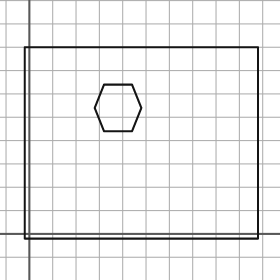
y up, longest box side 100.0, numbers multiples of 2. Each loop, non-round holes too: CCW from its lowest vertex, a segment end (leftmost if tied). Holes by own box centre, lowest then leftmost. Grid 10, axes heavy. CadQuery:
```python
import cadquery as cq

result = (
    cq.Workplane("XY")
    .moveTo(-2.0, -2.0)
    .lineTo(98.0, -2.0)
    .lineTo(98.0, 80.0)
    .lineTo(-2.0, 80.0)
    .close()
    .moveTo(32.0, 44.0)
    .lineTo(44.0, 44.0)
    .lineTo(48.0, 54.0)
    .lineTo(44.0, 64.0)
    .lineTo(32.0, 64.0)
    .lineTo(28.0, 54.0)
    .close()
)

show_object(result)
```